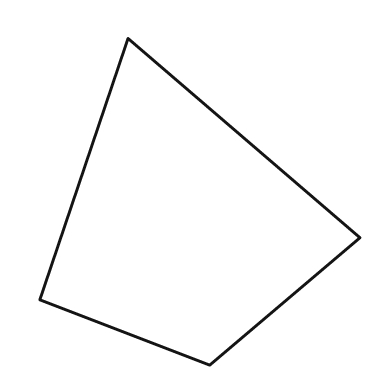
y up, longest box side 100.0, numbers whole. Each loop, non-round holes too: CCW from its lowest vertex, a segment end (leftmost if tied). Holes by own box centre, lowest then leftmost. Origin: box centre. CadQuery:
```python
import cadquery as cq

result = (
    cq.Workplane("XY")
    .moveTo(3.0, -50.0)
    .lineTo(49.0, -11.0)
    .lineTo(-22.0, 50.0)
    .lineTo(-49.0, -30.0)
    .close()
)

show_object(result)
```